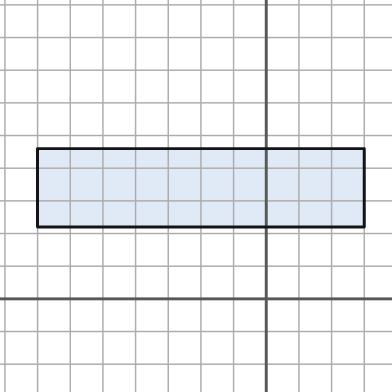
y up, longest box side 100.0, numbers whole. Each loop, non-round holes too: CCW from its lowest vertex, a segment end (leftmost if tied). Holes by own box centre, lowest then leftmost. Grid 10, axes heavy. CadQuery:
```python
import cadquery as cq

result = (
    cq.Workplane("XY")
    .moveTo(-70.0, 22.0)
    .lineTo(30.0, 22.0)
    .lineTo(30.0, 46.0)
    .lineTo(-70.0, 46.0)
    .close()
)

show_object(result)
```